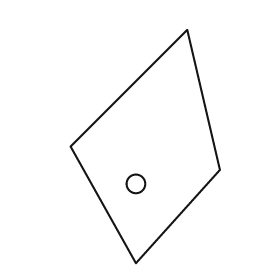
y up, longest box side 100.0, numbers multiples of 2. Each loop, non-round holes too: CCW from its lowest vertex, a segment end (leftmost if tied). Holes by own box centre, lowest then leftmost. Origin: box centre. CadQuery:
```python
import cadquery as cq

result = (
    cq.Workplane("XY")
    .moveTo(-4.0, -50.0)
    .lineTo(32.0, -10.0)
    .lineTo(18.0, 50.0)
    .lineTo(-32.0, 0.0)
    .close()
    .moveTo(-4.0, -16.0)
    .circle(4.0)
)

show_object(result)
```